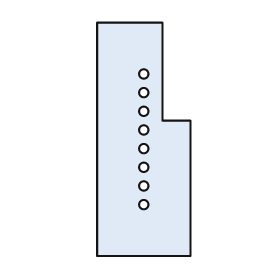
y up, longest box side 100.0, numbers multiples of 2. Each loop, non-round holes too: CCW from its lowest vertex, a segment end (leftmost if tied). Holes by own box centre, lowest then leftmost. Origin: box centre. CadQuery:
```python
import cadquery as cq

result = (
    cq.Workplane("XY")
    .moveTo(-20.0, -50.0)
    .lineTo(20.0, -50.0)
    .lineTo(20.0, 8.0)
    .lineTo(8.0, 8.0)
    .lineTo(8.0, 50.0)
    .lineTo(-20.0, 50.0)
    .close()
    .moveTo(0.0, -28.0)
    .circle(2.0)
    .moveTo(0.0, -20.0)
    .circle(2.0)
    .moveTo(0.0, -12.0)
    .circle(2.0)
    .moveTo(0.0, -4.0)
    .circle(2.0)
    .moveTo(0.0, 4.0)
    .circle(2.0)
    .moveTo(0.0, 12.0)
    .circle(2.0)
    .moveTo(0.0, 20.0)
    .circle(2.0)
    .moveTo(0.0, 28.0)
    .circle(2.0)
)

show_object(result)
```